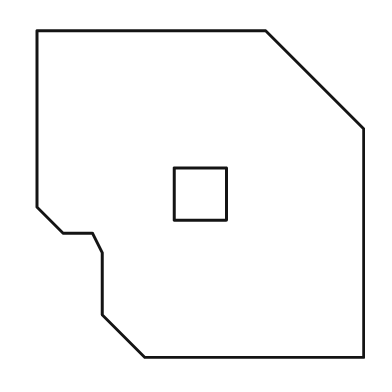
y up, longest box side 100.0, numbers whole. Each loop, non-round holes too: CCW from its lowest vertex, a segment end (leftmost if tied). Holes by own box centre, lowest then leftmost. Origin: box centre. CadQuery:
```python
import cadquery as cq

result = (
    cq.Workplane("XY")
    .moveTo(-17.0, -50.0)
    .lineTo(50.0, -50.0)
    .lineTo(50.0, 20.0)
    .lineTo(20.0, 50.0)
    .lineTo(-50.0, 50.0)
    .lineTo(-50.0, -4.0)
    .lineTo(-42.0, -12.0)
    .lineTo(-33.0, -12.0)
    .lineTo(-30.0, -18.0)
    .lineTo(-30.0, -37.0)
    .close()
    .moveTo(-8.0, -8.0)
    .lineTo(8.0, -8.0)
    .lineTo(8.0, 8.0)
    .lineTo(-8.0, 8.0)
    .close()
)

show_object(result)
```